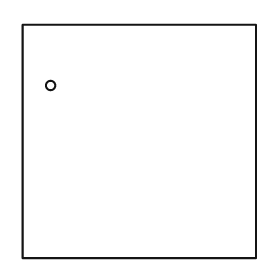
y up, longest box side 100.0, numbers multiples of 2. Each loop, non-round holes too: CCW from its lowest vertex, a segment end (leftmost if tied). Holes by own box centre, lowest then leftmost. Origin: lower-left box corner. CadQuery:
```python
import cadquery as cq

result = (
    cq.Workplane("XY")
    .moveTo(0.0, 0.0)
    .lineTo(100.0, 0.0)
    .lineTo(100.0, 100.0)
    .lineTo(0.0, 100.0)
    .close()
    .moveTo(12.0, 74.0)
    .circle(2.0)
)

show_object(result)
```